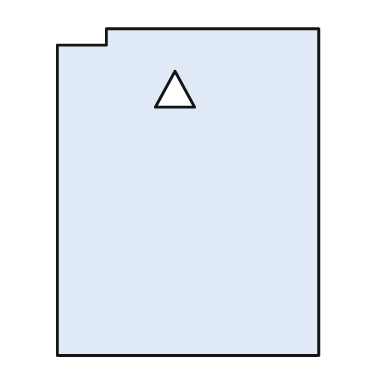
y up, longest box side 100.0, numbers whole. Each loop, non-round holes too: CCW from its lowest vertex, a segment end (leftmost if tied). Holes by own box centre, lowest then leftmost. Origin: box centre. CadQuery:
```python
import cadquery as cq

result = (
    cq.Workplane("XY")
    .moveTo(-40.0, -50.0)
    .lineTo(40.0, -50.0)
    .lineTo(40.0, 50.0)
    .lineTo(-25.0, 50.0)
    .lineTo(-25.0, 45.0)
    .lineTo(-40.0, 45.0)
    .close()
    .moveTo(-10.0, 26.0)
    .lineTo(2.0, 26.0)
    .lineTo(-4.0, 37.0)
    .close()
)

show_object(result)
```